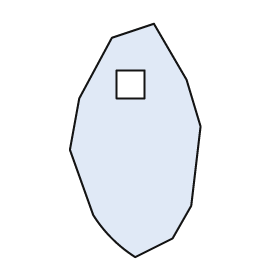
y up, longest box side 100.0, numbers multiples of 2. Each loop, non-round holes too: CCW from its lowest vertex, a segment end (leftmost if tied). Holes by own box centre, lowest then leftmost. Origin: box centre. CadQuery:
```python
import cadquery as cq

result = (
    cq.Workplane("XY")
    .moveTo(0.0, -50.0)
    .lineTo(16.0, -42.0)
    .lineTo(24.0, -28.0)
    .lineTo(28.0, 6.0)
    .lineTo(22.0, 26.0)
    .lineTo(8.0, 50.0)
    .lineTo(-10.0, 44.0)
    .lineTo(-24.0, 18.0)
    .lineTo(-28.0, -4.0)
    .lineTo(-18.0, -32.0)
    .threePointArc((-10.0, -42.0), (0.0, -50.0))
    .close()
    .moveTo(-8.0, 18.0)
    .lineTo(4.0, 18.0)
    .lineTo(4.0, 30.0)
    .lineTo(-8.0, 30.0)
    .close()
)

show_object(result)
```